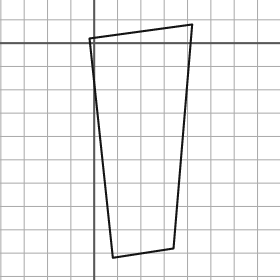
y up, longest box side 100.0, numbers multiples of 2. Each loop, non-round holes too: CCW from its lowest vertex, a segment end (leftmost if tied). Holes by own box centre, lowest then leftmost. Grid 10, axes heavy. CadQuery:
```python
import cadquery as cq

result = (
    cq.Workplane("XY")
    .moveTo(8.0, -92.0)
    .lineTo(34.0, -88.0)
    .lineTo(42.0, 8.0)
    .lineTo(-2.0, 2.0)
    .close()
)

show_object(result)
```